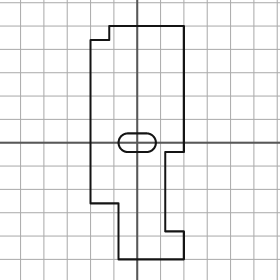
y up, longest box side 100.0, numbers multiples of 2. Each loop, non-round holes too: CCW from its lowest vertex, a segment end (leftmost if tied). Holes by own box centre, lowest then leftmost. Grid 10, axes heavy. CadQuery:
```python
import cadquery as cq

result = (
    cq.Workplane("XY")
    .moveTo(-8.0, -50.0)
    .lineTo(20.0, -50.0)
    .lineTo(20.0, -38.0)
    .lineTo(12.0, -38.0)
    .lineTo(12.0, -4.0)
    .lineTo(20.0, -4.0)
    .lineTo(20.0, 50.0)
    .lineTo(-12.0, 50.0)
    .lineTo(-12.0, 44.0)
    .lineTo(-20.0, 44.0)
    .lineTo(-20.0, -26.0)
    .lineTo(-8.0, -26.0)
    .close()
    .moveTo(-4.0, -4.0)
    .lineTo(4.0, -4.0)
    .threePointArc((8.0, 0.0), (4.0, 4.0))
    .lineTo(-4.0, 4.0)
    .threePointArc((-8.0, 0.0), (-4.0, -4.0))
    .close()
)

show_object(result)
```